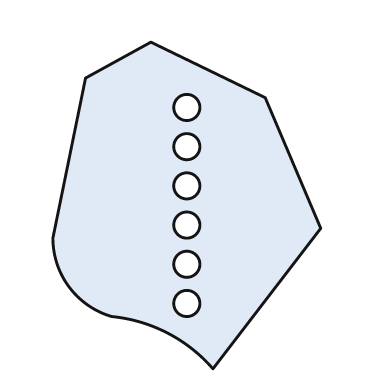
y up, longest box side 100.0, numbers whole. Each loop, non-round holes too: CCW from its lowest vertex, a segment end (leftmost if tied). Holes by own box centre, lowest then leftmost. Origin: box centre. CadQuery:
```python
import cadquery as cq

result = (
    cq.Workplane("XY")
    .moveTo(8.0, -50.0)
    .lineTo(41.0, -7.0)
    .lineTo(24.0, 33.0)
    .lineTo(-11.0, 50.0)
    .lineTo(-31.0, 39.0)
    .lineTo(-41.0, -10.0)
    .threePointArc((-36.0, -25.0), (-23.0, -34.0))
    .threePointArc((-6.0, -39.0), (8.0, -50.0))
    .close()
    .moveTo(0.0, -30.0)
    .circle(4.0)
    .moveTo(0.0, -18.0)
    .circle(4.0)
    .moveTo(0.0, -6.0)
    .circle(4.0)
    .moveTo(0.0, 6.0)
    .circle(4.0)
    .moveTo(0.0, 18.0)
    .circle(4.0)
    .moveTo(0.0, 30.0)
    .circle(4.0)
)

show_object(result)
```